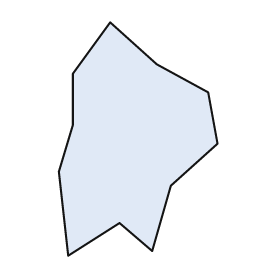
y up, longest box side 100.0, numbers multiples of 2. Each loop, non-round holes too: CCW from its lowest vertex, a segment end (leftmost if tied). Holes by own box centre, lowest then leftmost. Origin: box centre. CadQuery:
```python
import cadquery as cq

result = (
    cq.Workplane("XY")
    .moveTo(-30.0, -50.0)
    .lineTo(-8.0, -36.0)
    .lineTo(6.0, -48.0)
    .lineTo(14.0, -20.0)
    .lineTo(34.0, -2.0)
    .lineTo(30.0, 20.0)
    .lineTo(8.0, 32.0)
    .lineTo(-12.0, 50.0)
    .lineTo(-28.0, 28.0)
    .lineTo(-28.0, 6.0)
    .lineTo(-34.0, -14.0)
    .close()
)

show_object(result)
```